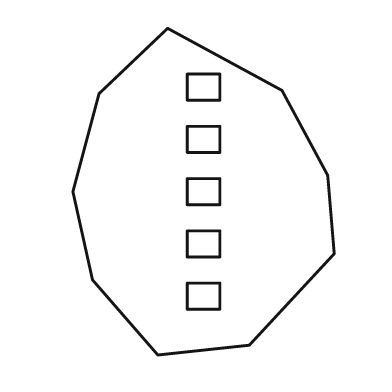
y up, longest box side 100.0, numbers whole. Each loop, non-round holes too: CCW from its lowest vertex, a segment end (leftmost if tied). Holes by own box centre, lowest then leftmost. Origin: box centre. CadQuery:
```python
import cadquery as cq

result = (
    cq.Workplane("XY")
    .moveTo(-14.0, -50.0)
    .lineTo(14.0, -47.0)
    .lineTo(40.0, -19.0)
    .lineTo(38.0, 5.0)
    .lineTo(24.0, 31.0)
    .lineTo(-11.0, 50.0)
    .lineTo(-32.0, 30.0)
    .lineTo(-40.0, 0.0)
    .lineTo(-34.0, -27.0)
    .close()
    .moveTo(-5.0, -36.0)
    .lineTo(5.0, -36.0)
    .lineTo(5.0, -28.0)
    .lineTo(-5.0, -28.0)
    .close()
    .moveTo(-5.0, -20.0)
    .lineTo(5.0, -20.0)
    .lineTo(5.0, -12.0)
    .lineTo(-5.0, -12.0)
    .close()
    .moveTo(-5.0, -4.0)
    .lineTo(5.0, -4.0)
    .lineTo(5.0, 4.0)
    .lineTo(-5.0, 4.0)
    .close()
    .moveTo(-5.0, 12.0)
    .lineTo(5.0, 12.0)
    .lineTo(5.0, 20.0)
    .lineTo(-5.0, 20.0)
    .close()
    .moveTo(-5.0, 28.0)
    .lineTo(5.0, 28.0)
    .lineTo(5.0, 36.0)
    .lineTo(-5.0, 36.0)
    .close()
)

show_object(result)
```